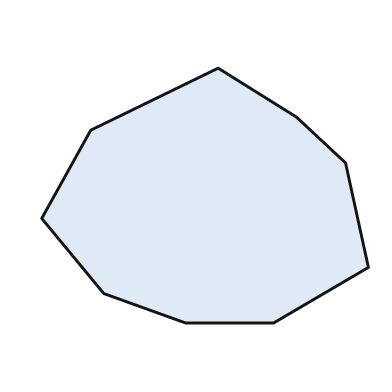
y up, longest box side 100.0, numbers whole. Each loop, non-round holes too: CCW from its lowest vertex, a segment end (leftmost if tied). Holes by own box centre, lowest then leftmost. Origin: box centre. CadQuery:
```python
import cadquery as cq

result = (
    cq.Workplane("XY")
    .moveTo(-6.0, -39.0)
    .lineTo(21.0, -39.0)
    .lineTo(50.0, -22.0)
    .lineTo(43.0, 10.0)
    .lineTo(28.0, 24.0)
    .lineTo(4.0, 39.0)
    .lineTo(-35.0, 20.0)
    .lineTo(-50.0, -7.0)
    .lineTo(-31.0, -30.0)
    .close()
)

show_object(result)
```